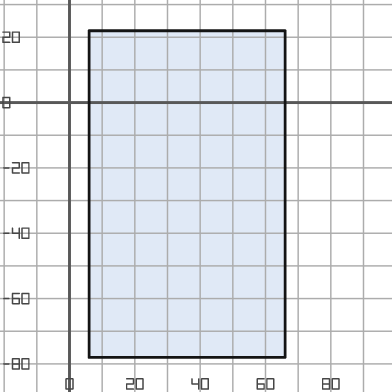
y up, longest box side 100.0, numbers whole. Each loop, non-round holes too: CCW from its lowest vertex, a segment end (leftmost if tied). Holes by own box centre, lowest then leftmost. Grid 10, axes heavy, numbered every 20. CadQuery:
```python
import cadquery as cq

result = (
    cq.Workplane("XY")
    .moveTo(6.0, -78.0)
    .lineTo(66.0, -78.0)
    .lineTo(66.0, 22.0)
    .lineTo(6.0, 22.0)
    .close()
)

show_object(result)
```